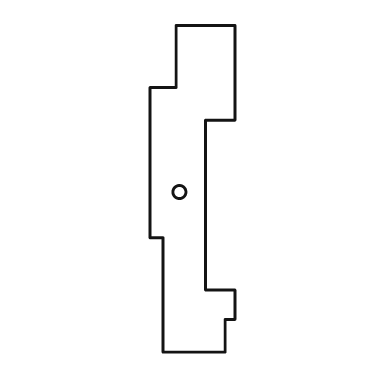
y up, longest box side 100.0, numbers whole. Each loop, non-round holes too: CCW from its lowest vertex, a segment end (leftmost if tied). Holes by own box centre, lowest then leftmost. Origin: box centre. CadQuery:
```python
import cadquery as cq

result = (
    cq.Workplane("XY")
    .moveTo(-9.0, -50.0)
    .lineTo(10.0, -50.0)
    .lineTo(10.0, -40.0)
    .lineTo(13.0, -40.0)
    .lineTo(13.0, -31.0)
    .lineTo(4.0, -31.0)
    .lineTo(4.0, 21.0)
    .lineTo(13.0, 21.0)
    .lineTo(13.0, 50.0)
    .lineTo(-5.0, 50.0)
    .lineTo(-5.0, 31.0)
    .lineTo(-13.0, 31.0)
    .lineTo(-13.0, -15.0)
    .lineTo(-9.0, -15.0)
    .close()
    .moveTo(-4.0, -1.0)
    .circle(2.0)
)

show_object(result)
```